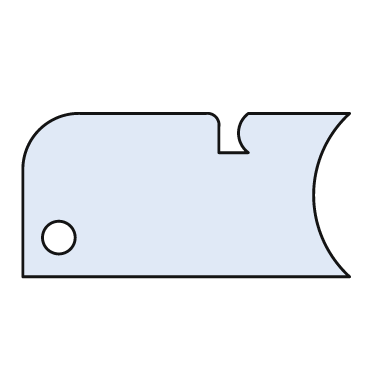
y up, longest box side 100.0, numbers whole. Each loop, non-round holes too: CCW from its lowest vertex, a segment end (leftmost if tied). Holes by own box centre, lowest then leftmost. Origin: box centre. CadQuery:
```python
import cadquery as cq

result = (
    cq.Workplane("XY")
    .moveTo(-50.0, -25.0)
    .lineTo(50.0, -25.0)
    .threePointArc((39.0, 0.0), (50.0, 25.0))
    .lineTo(19.0, 25.0)
    .threePointArc((16.0, 19.0), (19.0, 13.0))
    .lineTo(10.0, 13.0)
    .lineTo(10.0, 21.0)
    .threePointArc((9.0, 24.0), (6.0, 25.0))
    .lineTo(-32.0, 25.0)
    .threePointArc((-45.0, 20.0), (-50.0, 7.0))
    .close()
    .moveTo(-39.0, -13.0)
    .circle(5.0)
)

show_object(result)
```